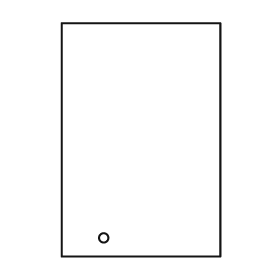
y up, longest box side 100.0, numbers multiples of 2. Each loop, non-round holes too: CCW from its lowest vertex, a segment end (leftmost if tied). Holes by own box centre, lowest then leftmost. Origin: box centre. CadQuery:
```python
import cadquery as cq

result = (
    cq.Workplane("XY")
    .moveTo(-34.0, -50.0)
    .lineTo(34.0, -50.0)
    .lineTo(34.0, 50.0)
    .lineTo(-34.0, 50.0)
    .close()
    .moveTo(-16.0, -42.0)
    .circle(2.0)
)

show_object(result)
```